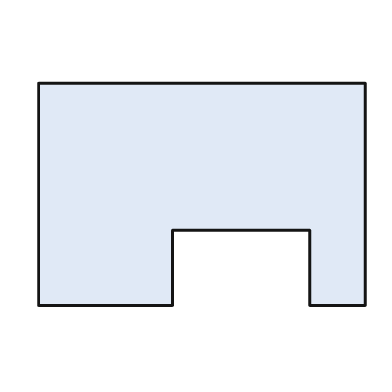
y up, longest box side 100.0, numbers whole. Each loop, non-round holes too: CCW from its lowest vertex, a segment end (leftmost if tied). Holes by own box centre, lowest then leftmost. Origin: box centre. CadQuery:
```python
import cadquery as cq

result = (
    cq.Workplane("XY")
    .moveTo(-50.0, -34.0)
    .lineTo(-9.0, -34.0)
    .lineTo(-9.0, -11.0)
    .lineTo(33.0, -11.0)
    .lineTo(33.0, -34.0)
    .lineTo(50.0, -34.0)
    .lineTo(50.0, 34.0)
    .lineTo(-50.0, 34.0)
    .close()
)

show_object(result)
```